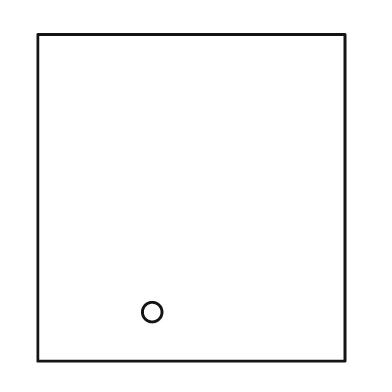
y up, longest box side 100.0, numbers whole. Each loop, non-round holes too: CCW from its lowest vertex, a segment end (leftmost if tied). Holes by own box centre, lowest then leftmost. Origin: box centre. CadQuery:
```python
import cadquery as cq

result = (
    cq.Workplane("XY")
    .moveTo(-47.0, -50.0)
    .lineTo(47.0, -50.0)
    .lineTo(47.0, 50.0)
    .lineTo(-47.0, 50.0)
    .close()
    .moveTo(-12.0, -35.0)
    .circle(3.0)
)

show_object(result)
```